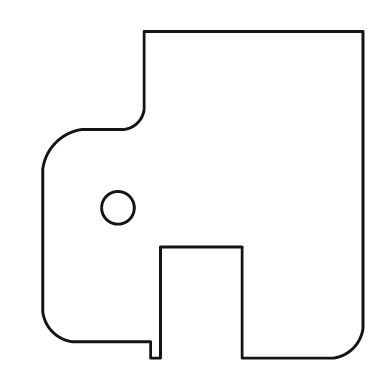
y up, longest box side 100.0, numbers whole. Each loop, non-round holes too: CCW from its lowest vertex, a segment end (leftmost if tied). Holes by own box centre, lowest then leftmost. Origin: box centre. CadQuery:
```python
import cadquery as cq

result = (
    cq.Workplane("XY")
    .moveTo(-16.0, -50.0)
    .lineTo(-13.0, -50.0)
    .lineTo(-13.0, -16.0)
    .lineTo(12.0, -16.0)
    .lineTo(12.0, -50.0)
    .lineTo(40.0, -50.0)
    .threePointArc((46.0, -47.0), (49.0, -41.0))
    .lineTo(49.0, 50.0)
    .lineTo(-18.0, 50.0)
    .lineTo(-18.0, 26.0)
    .threePointArc((-20.0, 22.0), (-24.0, 20.0))
    .lineTo(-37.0, 20.0)
    .threePointArc((-45.0, 16.0), (-49.0, 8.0))
    .lineTo(-49.0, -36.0)
    .threePointArc((-46.0, -42.0), (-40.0, -45.0))
    .lineTo(-16.0, -45.0)
    .close()
    .moveTo(-26.0, -4.0)
    .circle(5.0)
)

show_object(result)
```